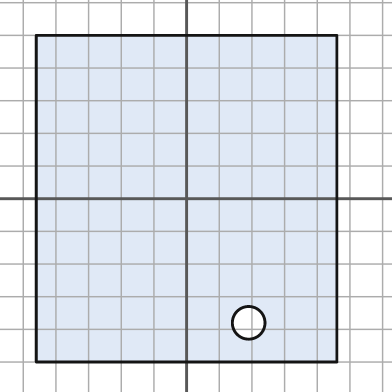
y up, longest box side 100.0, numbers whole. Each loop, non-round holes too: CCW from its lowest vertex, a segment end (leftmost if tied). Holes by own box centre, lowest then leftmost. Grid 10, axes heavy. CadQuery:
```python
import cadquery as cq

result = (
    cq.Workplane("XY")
    .moveTo(-46.0, -50.0)
    .lineTo(46.0, -50.0)
    .lineTo(46.0, 50.0)
    .lineTo(-46.0, 50.0)
    .close()
    .moveTo(19.0, -38.0)
    .circle(5.0)
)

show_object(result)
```